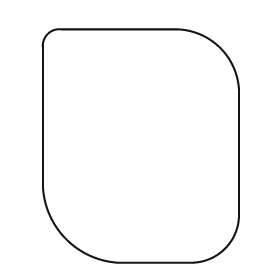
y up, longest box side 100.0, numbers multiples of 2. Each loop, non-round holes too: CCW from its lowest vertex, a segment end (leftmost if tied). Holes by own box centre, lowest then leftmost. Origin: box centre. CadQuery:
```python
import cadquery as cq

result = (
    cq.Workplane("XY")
    .moveTo(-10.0, -50.0)
    .lineTo(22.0, -50.0)
    .threePointArc((36.0, -44.0), (42.0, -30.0))
    .lineTo(42.0, 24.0)
    .threePointArc((34.0, 42.0), (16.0, 50.0))
    .lineTo(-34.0, 50.0)
    .threePointArc((-40.0, 48.0), (-42.0, 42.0))
    .lineTo(-42.0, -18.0)
    .threePointArc((-32.0, -40.0), (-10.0, -50.0))
    .close()
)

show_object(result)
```